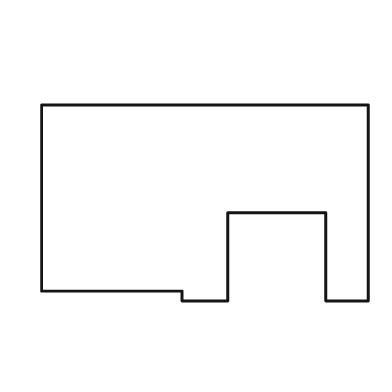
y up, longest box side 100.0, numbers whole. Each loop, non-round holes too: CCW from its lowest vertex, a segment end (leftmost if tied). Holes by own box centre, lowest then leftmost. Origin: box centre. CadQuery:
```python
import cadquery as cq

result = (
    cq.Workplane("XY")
    .moveTo(-7.0, -30.0)
    .lineTo(7.0, -30.0)
    .lineTo(7.0, -3.0)
    .lineTo(37.0, -3.0)
    .lineTo(37.0, -30.0)
    .lineTo(50.0, -30.0)
    .lineTo(50.0, 30.0)
    .lineTo(-50.0, 30.0)
    .lineTo(-50.0, -27.0)
    .lineTo(-7.0, -27.0)
    .close()
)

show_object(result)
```